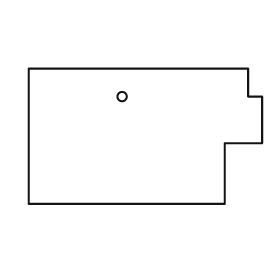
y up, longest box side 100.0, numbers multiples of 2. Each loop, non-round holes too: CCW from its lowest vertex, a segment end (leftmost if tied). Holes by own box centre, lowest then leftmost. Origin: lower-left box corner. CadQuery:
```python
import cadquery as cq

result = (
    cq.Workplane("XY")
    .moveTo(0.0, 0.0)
    .lineTo(84.0, 0.0)
    .lineTo(84.0, 26.0)
    .lineTo(100.0, 26.0)
    .lineTo(100.0, 46.0)
    .lineTo(94.0, 46.0)
    .lineTo(94.0, 58.0)
    .lineTo(0.0, 58.0)
    .close()
    .moveTo(40.0, 46.0)
    .circle(2.0)
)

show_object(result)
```